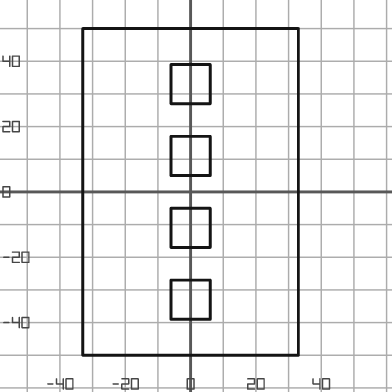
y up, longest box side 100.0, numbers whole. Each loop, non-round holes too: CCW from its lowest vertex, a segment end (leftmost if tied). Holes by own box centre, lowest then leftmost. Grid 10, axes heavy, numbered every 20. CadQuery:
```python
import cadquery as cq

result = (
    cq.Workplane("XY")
    .moveTo(-33.0, -50.0)
    .lineTo(33.0, -50.0)
    .lineTo(33.0, 50.0)
    .lineTo(-33.0, 50.0)
    .close()
    .moveTo(-6.0, -39.0)
    .lineTo(6.0, -39.0)
    .lineTo(6.0, -27.0)
    .lineTo(-6.0, -27.0)
    .close()
    .moveTo(-6.0, -17.0)
    .lineTo(6.0, -17.0)
    .lineTo(6.0, -5.0)
    .lineTo(-6.0, -5.0)
    .close()
    .moveTo(-6.0, 5.0)
    .lineTo(6.0, 5.0)
    .lineTo(6.0, 17.0)
    .lineTo(-6.0, 17.0)
    .close()
    .moveTo(-6.0, 27.0)
    .lineTo(6.0, 27.0)
    .lineTo(6.0, 39.0)
    .lineTo(-6.0, 39.0)
    .close()
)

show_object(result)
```